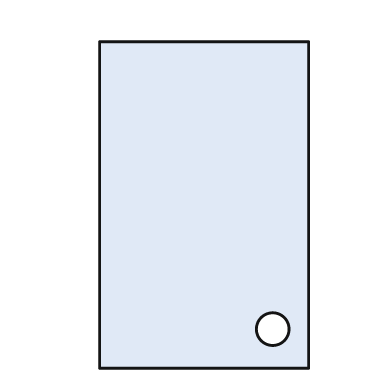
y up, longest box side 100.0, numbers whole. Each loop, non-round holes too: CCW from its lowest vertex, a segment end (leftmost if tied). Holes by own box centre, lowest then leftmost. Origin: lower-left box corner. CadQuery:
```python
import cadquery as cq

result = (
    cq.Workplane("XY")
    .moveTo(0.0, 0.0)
    .lineTo(64.0, 0.0)
    .lineTo(64.0, 100.0)
    .lineTo(0.0, 100.0)
    .close()
    .moveTo(53.0, 12.0)
    .circle(5.0)
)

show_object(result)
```